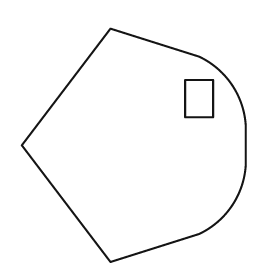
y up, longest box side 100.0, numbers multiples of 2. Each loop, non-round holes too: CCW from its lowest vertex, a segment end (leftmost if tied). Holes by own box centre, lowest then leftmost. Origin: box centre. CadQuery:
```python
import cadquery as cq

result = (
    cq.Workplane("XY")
    .moveTo(-10.0, -50.0)
    .lineTo(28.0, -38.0)
    .threePointArc((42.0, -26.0), (48.0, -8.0))
    .lineTo(48.0, 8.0)
    .threePointArc((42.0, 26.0), (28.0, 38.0))
    .lineTo(-10.0, 50.0)
    .lineTo(-48.0, 0.0)
    .close()
    .moveTo(22.0, 12.0)
    .lineTo(34.0, 12.0)
    .lineTo(34.0, 28.0)
    .lineTo(22.0, 28.0)
    .close()
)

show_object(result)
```